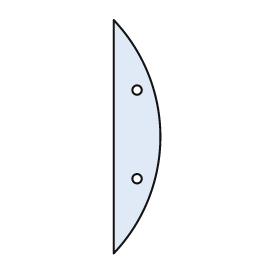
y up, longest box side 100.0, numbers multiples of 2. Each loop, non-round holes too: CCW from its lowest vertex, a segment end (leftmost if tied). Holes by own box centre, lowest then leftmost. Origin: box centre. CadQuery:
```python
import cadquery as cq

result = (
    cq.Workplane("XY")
    .moveTo(-10.0, -50.0)
    .threePointArc((10.0, 0.0), (-10.0, 50.0))
    .close()
    .moveTo(0.0, -18.0)
    .circle(2.0)
    .moveTo(0.0, 20.0)
    .circle(2.0)
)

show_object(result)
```